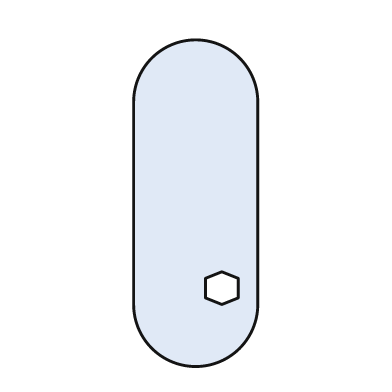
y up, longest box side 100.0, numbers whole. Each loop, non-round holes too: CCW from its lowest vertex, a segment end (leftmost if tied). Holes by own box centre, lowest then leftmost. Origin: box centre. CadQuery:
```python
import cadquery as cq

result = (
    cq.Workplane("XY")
    .moveTo(-19.0, -31.0)
    .threePointArc((0.0, -50.0), (19.0, -31.0))
    .lineTo(19.0, 31.0)
    .threePointArc((0.0, 50.0), (-19.0, 31.0))
    .close()
    .moveTo(8.0, -31.0)
    .lineTo(13.0, -29.0)
    .lineTo(13.0, -23.0)
    .lineTo(8.0, -21.0)
    .lineTo(3.0, -23.0)
    .lineTo(3.0, -29.0)
    .close()
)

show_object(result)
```